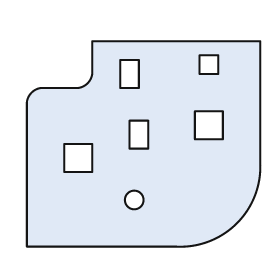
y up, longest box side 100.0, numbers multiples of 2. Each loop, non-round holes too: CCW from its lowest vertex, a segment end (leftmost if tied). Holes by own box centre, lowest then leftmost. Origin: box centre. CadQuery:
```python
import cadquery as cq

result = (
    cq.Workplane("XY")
    .moveTo(-50.0, -44.0)
    .lineTo(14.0, -44.0)
    .threePointArc((40.0, -34.0), (50.0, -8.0))
    .lineTo(50.0, 44.0)
    .lineTo(-22.0, 44.0)
    .lineTo(-22.0, 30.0)
    .threePointArc((-24.0, 26.0), (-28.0, 24.0))
    .lineTo(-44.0, 24.0)
    .threePointArc((-48.0, 22.0), (-50.0, 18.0))
    .close()
    .moveTo(-4.0, -24.0)
    .circle(4.0)
    .moveTo(-34.0, -12.0)
    .lineTo(-22.0, -12.0)
    .lineTo(-22.0, 0.0)
    .lineTo(-34.0, 0.0)
    .close()
    .moveTo(-6.0, -2.0)
    .lineTo(2.0, -2.0)
    .lineTo(2.0, 10.0)
    .lineTo(-6.0, 10.0)
    .close()
    .moveTo(22.0, 2.0)
    .lineTo(34.0, 2.0)
    .lineTo(34.0, 14.0)
    .lineTo(22.0, 14.0)
    .close()
    .moveTo(-10.0, 24.0)
    .lineTo(-2.0, 24.0)
    .lineTo(-2.0, 36.0)
    .lineTo(-10.0, 36.0)
    .close()
    .moveTo(24.0, 30.0)
    .lineTo(32.0, 30.0)
    .lineTo(32.0, 38.0)
    .lineTo(24.0, 38.0)
    .close()
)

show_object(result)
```